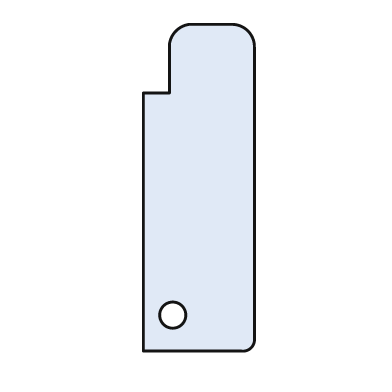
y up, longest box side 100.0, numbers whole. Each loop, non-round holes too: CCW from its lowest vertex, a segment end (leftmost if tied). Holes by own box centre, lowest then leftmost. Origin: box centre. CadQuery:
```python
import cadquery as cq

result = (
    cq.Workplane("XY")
    .moveTo(-17.0, -50.0)
    .lineTo(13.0, -50.0)
    .threePointArc((16.0, -49.0), (17.0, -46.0))
    .lineTo(17.0, 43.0)
    .threePointArc((15.0, 48.0), (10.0, 50.0))
    .lineTo(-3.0, 50.0)
    .threePointArc((-7.0, 48.0), (-9.0, 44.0))
    .lineTo(-9.0, 29.0)
    .lineTo(-17.0, 29.0)
    .close()
    .moveTo(-8.0, -39.0)
    .circle(4.0)
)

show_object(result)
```